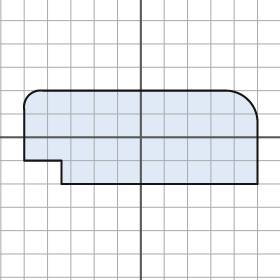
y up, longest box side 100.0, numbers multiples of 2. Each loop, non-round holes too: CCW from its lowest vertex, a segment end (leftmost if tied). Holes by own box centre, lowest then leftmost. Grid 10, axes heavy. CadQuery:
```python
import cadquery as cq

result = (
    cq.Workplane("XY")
    .moveTo(-34.0, -20.0)
    .lineTo(50.0, -20.0)
    .lineTo(50.0, 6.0)
    .threePointArc((46.0, 16.0), (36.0, 20.0))
    .lineTo(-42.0, 20.0)
    .threePointArc((-48.0, 18.0), (-50.0, 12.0))
    .lineTo(-50.0, -10.0)
    .lineTo(-34.0, -10.0)
    .close()
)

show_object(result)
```